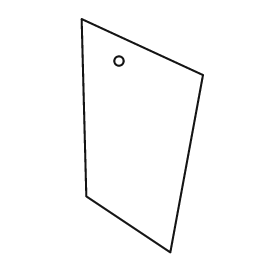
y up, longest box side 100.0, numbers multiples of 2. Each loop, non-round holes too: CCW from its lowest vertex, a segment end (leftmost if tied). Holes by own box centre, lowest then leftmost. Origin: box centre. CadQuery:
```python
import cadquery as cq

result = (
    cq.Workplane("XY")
    .moveTo(12.0, -50.0)
    .lineTo(26.0, 26.0)
    .lineTo(-26.0, 50.0)
    .lineTo(-24.0, -26.0)
    .close()
    .moveTo(-10.0, 32.0)
    .circle(2.0)
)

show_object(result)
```